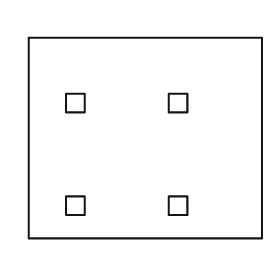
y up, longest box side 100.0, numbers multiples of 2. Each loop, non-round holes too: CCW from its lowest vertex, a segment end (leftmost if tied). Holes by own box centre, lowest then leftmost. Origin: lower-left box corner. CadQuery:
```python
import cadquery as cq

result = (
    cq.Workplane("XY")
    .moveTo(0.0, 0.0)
    .lineTo(100.0, 0.0)
    .lineTo(100.0, 86.0)
    .lineTo(0.0, 86.0)
    .close()
    .moveTo(16.0, 10.0)
    .lineTo(24.0, 10.0)
    .lineTo(24.0, 18.0)
    .lineTo(16.0, 18.0)
    .close()
    .moveTo(60.0, 10.0)
    .lineTo(68.0, 10.0)
    .lineTo(68.0, 18.0)
    .lineTo(60.0, 18.0)
    .close()
    .moveTo(16.0, 54.0)
    .lineTo(24.0, 54.0)
    .lineTo(24.0, 62.0)
    .lineTo(16.0, 62.0)
    .close()
    .moveTo(60.0, 54.0)
    .lineTo(68.0, 54.0)
    .lineTo(68.0, 62.0)
    .lineTo(60.0, 62.0)
    .close()
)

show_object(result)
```